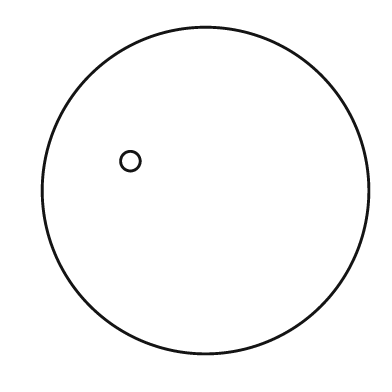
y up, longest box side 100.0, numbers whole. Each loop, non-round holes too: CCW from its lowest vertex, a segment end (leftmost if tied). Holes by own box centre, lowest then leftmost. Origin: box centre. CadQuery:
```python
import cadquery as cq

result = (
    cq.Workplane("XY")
    .moveTo(0.0, 0.0)
    .circle(50.0)
    .moveTo(-23.0, 9.0)
    .circle(3.0)
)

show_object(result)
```